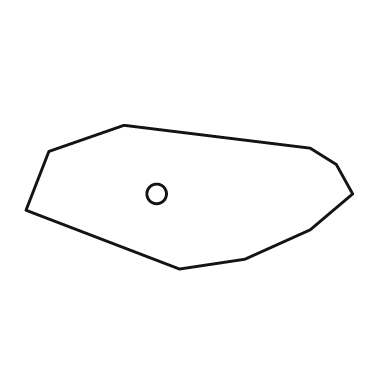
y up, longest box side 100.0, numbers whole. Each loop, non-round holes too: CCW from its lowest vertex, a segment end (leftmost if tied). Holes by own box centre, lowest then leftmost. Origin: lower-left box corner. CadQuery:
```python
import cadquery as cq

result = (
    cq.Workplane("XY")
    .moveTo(47.0, 0.0)
    .lineTo(67.0, 3.0)
    .lineTo(87.0, 12.0)
    .lineTo(100.0, 23.0)
    .lineTo(95.0, 32.0)
    .lineTo(87.0, 37.0)
    .lineTo(30.0, 44.0)
    .lineTo(7.0, 36.0)
    .lineTo(0.0, 18.0)
    .close()
    .moveTo(40.0, 23.0)
    .circle(3.0)
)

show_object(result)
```